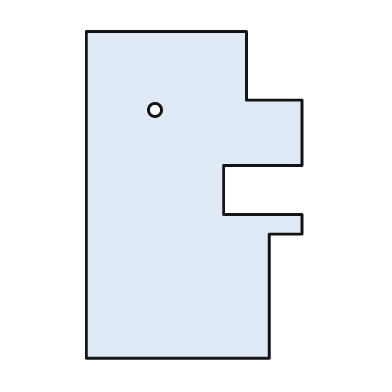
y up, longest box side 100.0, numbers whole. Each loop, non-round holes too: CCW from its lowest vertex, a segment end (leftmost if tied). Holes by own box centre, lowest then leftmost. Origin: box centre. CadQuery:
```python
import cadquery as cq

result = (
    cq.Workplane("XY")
    .moveTo(-33.0, -50.0)
    .lineTo(23.0, -50.0)
    .lineTo(23.0, -12.0)
    .lineTo(33.0, -12.0)
    .lineTo(33.0, -6.0)
    .lineTo(9.0, -6.0)
    .lineTo(9.0, 9.0)
    .lineTo(33.0, 9.0)
    .lineTo(33.0, 29.0)
    .lineTo(16.0, 29.0)
    .lineTo(16.0, 50.0)
    .lineTo(-33.0, 50.0)
    .close()
    .moveTo(-12.0, 26.0)
    .circle(2.0)
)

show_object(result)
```